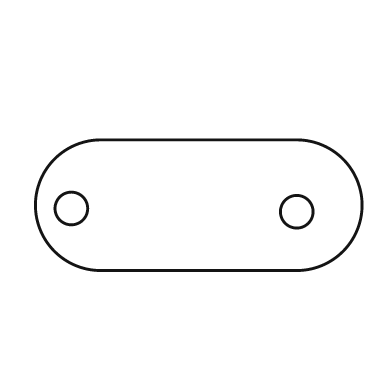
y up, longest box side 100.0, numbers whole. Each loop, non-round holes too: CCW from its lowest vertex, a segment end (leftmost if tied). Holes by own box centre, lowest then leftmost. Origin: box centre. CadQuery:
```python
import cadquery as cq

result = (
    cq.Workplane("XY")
    .moveTo(-30.0, -20.0)
    .lineTo(30.0, -20.0)
    .threePointArc((50.0, 0.0), (30.0, 20.0))
    .lineTo(-30.0, 20.0)
    .threePointArc((-50.0, 0.0), (-30.0, -20.0))
    .close()
    .moveTo(30.0, -2.0)
    .circle(5.0)
    .moveTo(-39.0, -1.0)
    .circle(5.0)
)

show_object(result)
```